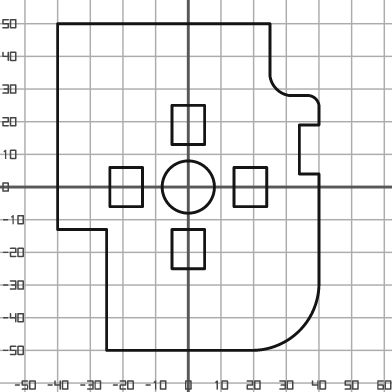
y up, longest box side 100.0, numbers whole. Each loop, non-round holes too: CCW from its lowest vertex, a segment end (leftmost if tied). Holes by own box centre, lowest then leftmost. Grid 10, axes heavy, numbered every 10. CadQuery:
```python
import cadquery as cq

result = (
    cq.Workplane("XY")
    .moveTo(-25.0, -50.0)
    .lineTo(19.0, -50.0)
    .threePointArc((34.0, -44.0), (40.0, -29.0))
    .lineTo(40.0, 4.0)
    .lineTo(34.0, 4.0)
    .lineTo(34.0, 19.0)
    .lineTo(40.0, 19.0)
    .lineTo(40.0, 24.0)
    .threePointArc((39.0, 27.0), (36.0, 28.0))
    .lineTo(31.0, 28.0)
    .threePointArc((27.0, 30.0), (25.0, 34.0))
    .lineTo(25.0, 50.0)
    .lineTo(-40.0, 50.0)
    .lineTo(-40.0, -13.0)
    .lineTo(-25.0, -13.0)
    .close()
    .moveTo(-5.0, -25.0)
    .lineTo(5.0, -25.0)
    .lineTo(5.0, -13.0)
    .lineTo(-5.0, -13.0)
    .close()
    .moveTo(-24.0, -6.0)
    .lineTo(-14.0, -6.0)
    .lineTo(-14.0, 6.0)
    .lineTo(-24.0, 6.0)
    .close()
    .moveTo(0.0, 0.0)
    .circle(8.0)
    .moveTo(14.0, -6.0)
    .lineTo(24.0, -6.0)
    .lineTo(24.0, 6.0)
    .lineTo(14.0, 6.0)
    .close()
    .moveTo(-5.0, 13.0)
    .lineTo(5.0, 13.0)
    .lineTo(5.0, 25.0)
    .lineTo(-5.0, 25.0)
    .close()
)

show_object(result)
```